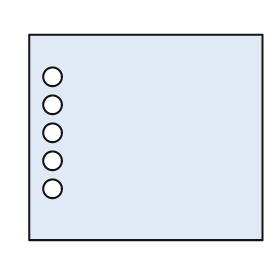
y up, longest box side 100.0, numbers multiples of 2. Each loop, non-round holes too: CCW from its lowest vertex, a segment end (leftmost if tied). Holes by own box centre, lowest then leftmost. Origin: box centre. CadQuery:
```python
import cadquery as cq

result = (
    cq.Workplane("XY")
    .moveTo(-50.0, -44.0)
    .lineTo(50.0, -44.0)
    .lineTo(50.0, 44.0)
    .lineTo(-50.0, 44.0)
    .close()
    .moveTo(-40.0, -22.0)
    .circle(4.0)
    .moveTo(-40.0, -10.0)
    .circle(4.0)
    .moveTo(-40.0, 2.0)
    .circle(4.0)
    .moveTo(-40.0, 14.0)
    .circle(4.0)
    .moveTo(-40.0, 26.0)
    .circle(4.0)
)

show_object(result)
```